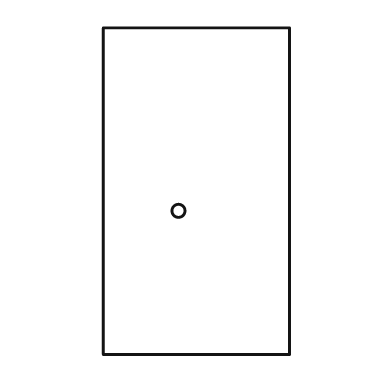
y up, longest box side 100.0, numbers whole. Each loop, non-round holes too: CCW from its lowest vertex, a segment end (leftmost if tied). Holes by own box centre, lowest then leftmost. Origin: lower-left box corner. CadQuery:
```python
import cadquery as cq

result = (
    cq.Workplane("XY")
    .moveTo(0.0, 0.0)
    .lineTo(57.0, 0.0)
    .lineTo(57.0, 100.0)
    .lineTo(0.0, 100.0)
    .close()
    .moveTo(23.0, 44.0)
    .circle(2.0)
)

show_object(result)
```